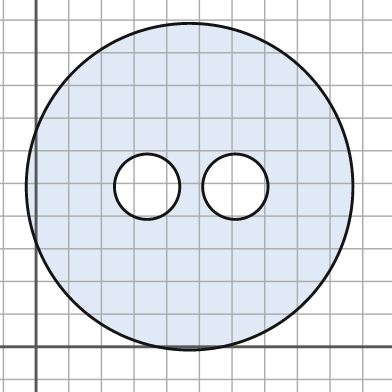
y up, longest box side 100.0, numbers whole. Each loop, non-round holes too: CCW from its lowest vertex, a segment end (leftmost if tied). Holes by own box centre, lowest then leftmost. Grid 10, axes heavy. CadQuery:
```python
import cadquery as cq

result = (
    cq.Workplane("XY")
    .moveTo(47.0, 49.0)
    .circle(50.0)
    .moveTo(34.0, 49.0)
    .circle(10.0)
    .moveTo(61.0, 49.0)
    .circle(10.0)
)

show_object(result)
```